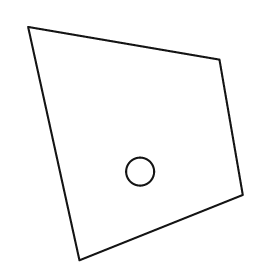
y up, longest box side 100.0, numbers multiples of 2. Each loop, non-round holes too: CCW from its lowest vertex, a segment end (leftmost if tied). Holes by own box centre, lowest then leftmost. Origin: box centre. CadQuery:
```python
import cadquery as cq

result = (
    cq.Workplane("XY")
    .moveTo(-24.0, -50.0)
    .lineTo(46.0, -22.0)
    .lineTo(36.0, 36.0)
    .lineTo(-46.0, 50.0)
    .close()
    .moveTo(2.0, -12.0)
    .circle(6.0)
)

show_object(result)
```